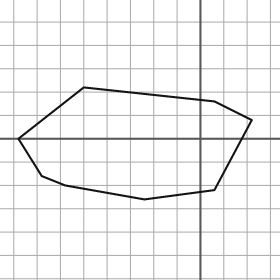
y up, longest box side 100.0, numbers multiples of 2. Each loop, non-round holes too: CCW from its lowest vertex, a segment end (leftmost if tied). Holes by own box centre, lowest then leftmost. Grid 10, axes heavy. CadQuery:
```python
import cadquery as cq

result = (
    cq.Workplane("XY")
    .moveTo(-24.0, -26.0)
    .lineTo(6.0, -22.0)
    .lineTo(22.0, 8.0)
    .lineTo(6.0, 16.0)
    .lineTo(-50.0, 22.0)
    .lineTo(-78.0, 0.0)
    .lineTo(-68.0, -16.0)
    .lineTo(-58.0, -20.0)
    .close()
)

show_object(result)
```